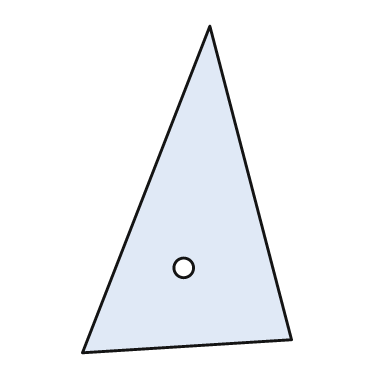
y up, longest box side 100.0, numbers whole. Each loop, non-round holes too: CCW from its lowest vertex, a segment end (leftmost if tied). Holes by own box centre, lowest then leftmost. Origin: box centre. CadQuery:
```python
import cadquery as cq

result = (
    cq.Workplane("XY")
    .moveTo(-32.0, -50.0)
    .lineTo(32.0, -46.0)
    .lineTo(7.0, 50.0)
    .close()
    .moveTo(-1.0, -24.0)
    .circle(3.0)
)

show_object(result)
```